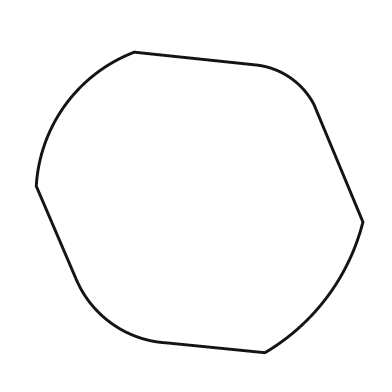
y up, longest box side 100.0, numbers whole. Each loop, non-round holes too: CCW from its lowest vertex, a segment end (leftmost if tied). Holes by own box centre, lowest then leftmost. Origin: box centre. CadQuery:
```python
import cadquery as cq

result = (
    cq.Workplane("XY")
    .moveTo(20.0, -46.0)
    .threePointArc((39.0, -29.0), (50.0, -6.0))
    .lineTo(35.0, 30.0)
    .threePointArc((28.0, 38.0), (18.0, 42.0))
    .lineTo(-20.0, 46.0)
    .threePointArc((-41.0, 30.0), (-50.0, 5.0))
    .lineTo(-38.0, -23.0)
    .threePointArc((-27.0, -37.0), (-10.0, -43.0))
    .close()
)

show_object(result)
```